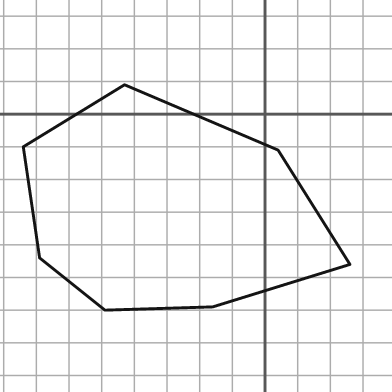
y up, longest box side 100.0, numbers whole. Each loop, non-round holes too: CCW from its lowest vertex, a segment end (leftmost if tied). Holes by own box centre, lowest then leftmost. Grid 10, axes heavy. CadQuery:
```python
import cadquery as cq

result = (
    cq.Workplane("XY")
    .moveTo(-49.0, -60.0)
    .lineTo(-16.0, -59.0)
    .lineTo(26.0, -46.0)
    .lineTo(4.0, -11.0)
    .lineTo(-43.0, 9.0)
    .lineTo(-74.0, -10.0)
    .lineTo(-69.0, -44.0)
    .close()
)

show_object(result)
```